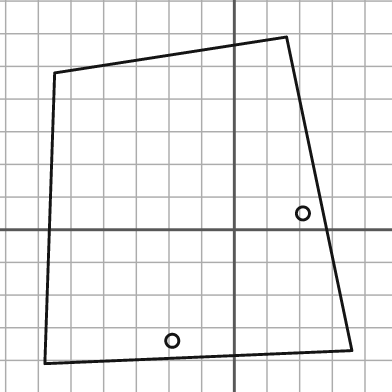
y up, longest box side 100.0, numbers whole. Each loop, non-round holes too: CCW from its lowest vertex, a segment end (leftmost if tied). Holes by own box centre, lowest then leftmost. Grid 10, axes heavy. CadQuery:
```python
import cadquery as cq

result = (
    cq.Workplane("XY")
    .moveTo(-58.0, -41.0)
    .lineTo(36.0, -37.0)
    .lineTo(16.0, 59.0)
    .lineTo(-55.0, 48.0)
    .close()
    .moveTo(-19.0, -34.0)
    .circle(2.0)
    .moveTo(21.0, 5.0)
    .circle(2.0)
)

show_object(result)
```